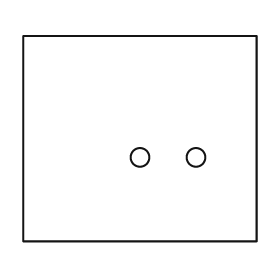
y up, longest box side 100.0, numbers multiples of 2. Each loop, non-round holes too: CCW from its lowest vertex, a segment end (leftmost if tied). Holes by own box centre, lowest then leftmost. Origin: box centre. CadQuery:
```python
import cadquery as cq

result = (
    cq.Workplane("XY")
    .moveTo(-50.0, -44.0)
    .lineTo(50.0, -44.0)
    .lineTo(50.0, 44.0)
    .lineTo(-50.0, 44.0)
    .close()
    .moveTo(0.0, -8.0)
    .circle(4.0)
    .moveTo(24.0, -8.0)
    .circle(4.0)
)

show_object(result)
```